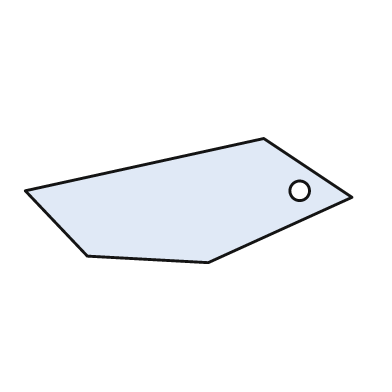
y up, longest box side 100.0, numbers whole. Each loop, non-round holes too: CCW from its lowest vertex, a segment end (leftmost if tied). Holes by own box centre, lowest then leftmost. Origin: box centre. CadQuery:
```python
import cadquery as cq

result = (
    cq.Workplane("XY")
    .moveTo(6.0, -19.0)
    .lineTo(50.0, 1.0)
    .lineTo(23.0, 19.0)
    .lineTo(-50.0, 3.0)
    .lineTo(-31.0, -17.0)
    .close()
    .moveTo(34.0, 3.0)
    .circle(3.0)
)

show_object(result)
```